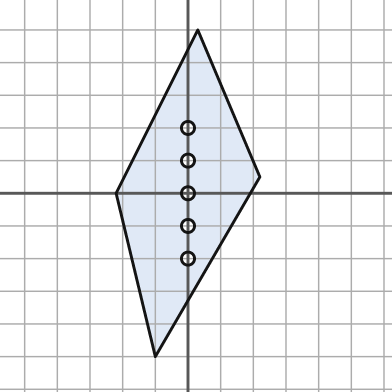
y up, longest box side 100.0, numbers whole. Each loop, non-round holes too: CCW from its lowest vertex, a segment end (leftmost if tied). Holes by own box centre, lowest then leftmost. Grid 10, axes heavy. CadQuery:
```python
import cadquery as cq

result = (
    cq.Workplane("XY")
    .moveTo(-10.0, -50.0)
    .lineTo(22.0, 5.0)
    .lineTo(3.0, 50.0)
    .lineTo(-22.0, 0.0)
    .close()
    .moveTo(0.0, -20.0)
    .circle(2.0)
    .moveTo(0.0, -10.0)
    .circle(2.0)
    .moveTo(0.0, 0.0)
    .circle(2.0)
    .moveTo(0.0, 10.0)
    .circle(2.0)
    .moveTo(0.0, 20.0)
    .circle(2.0)
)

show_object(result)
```